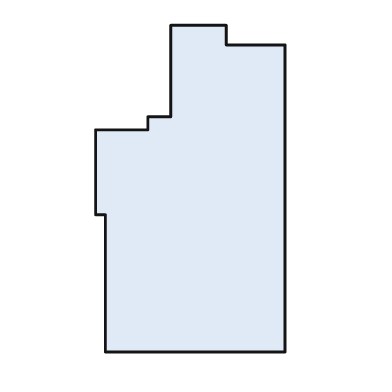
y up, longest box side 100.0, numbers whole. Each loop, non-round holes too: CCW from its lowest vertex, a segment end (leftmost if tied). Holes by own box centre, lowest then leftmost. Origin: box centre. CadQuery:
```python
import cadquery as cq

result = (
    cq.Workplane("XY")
    .moveTo(-26.0, -50.0)
    .lineTo(29.0, -50.0)
    .lineTo(29.0, 44.0)
    .lineTo(11.0, 44.0)
    .lineTo(11.0, 50.0)
    .lineTo(-6.0, 50.0)
    .lineTo(-6.0, 22.0)
    .lineTo(-13.0, 22.0)
    .lineTo(-13.0, 18.0)
    .lineTo(-29.0, 18.0)
    .lineTo(-29.0, -8.0)
    .lineTo(-26.0, -8.0)
    .close()
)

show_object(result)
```